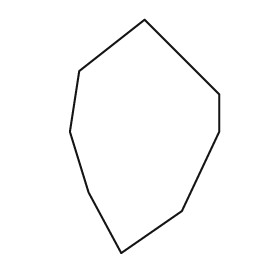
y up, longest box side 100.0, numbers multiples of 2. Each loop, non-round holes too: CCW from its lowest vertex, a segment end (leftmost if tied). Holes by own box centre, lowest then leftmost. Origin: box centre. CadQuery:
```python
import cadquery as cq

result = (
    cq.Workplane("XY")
    .moveTo(-10.0, -50.0)
    .lineTo(16.0, -32.0)
    .lineTo(32.0, 2.0)
    .lineTo(32.0, 18.0)
    .lineTo(0.0, 50.0)
    .lineTo(-28.0, 28.0)
    .lineTo(-32.0, 2.0)
    .lineTo(-24.0, -24.0)
    .close()
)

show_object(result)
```